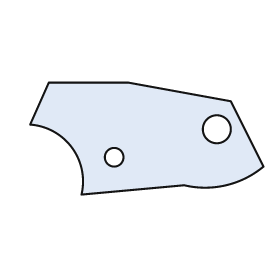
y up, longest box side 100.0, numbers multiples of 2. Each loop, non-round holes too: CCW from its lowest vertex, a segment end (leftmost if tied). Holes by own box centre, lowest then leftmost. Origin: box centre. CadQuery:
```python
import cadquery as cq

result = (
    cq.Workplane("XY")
    .moveTo(-28.0, -24.0)
    .lineTo(16.0, -20.0)
    .threePointArc((34.0, -20.0), (50.0, -12.0))
    .lineTo(36.0, 16.0)
    .lineTo(-8.0, 24.0)
    .lineTo(-42.0, 24.0)
    .lineTo(-50.0, 6.0)
    .threePointArc((-32.0, -4.0), (-28.0, -24.0))
    .close()
    .moveTo(-14.0, -8.0)
    .circle(4.0)
    .moveTo(30.0, 4.0)
    .circle(6.0)
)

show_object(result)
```